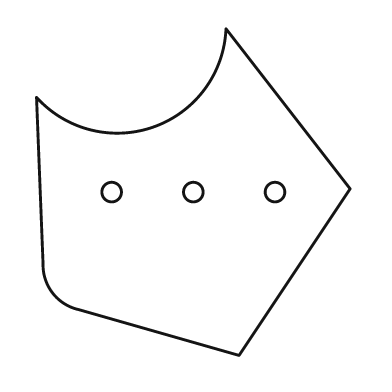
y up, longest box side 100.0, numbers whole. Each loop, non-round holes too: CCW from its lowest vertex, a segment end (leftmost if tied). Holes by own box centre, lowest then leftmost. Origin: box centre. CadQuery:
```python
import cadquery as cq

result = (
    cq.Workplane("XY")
    .moveTo(14.0, -50.0)
    .lineTo(48.0, 1.0)
    .lineTo(10.0, 50.0)
    .threePointArc((-12.0, 20.0), (-48.0, 29.0))
    .lineTo(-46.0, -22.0)
    .threePointArc((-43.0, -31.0), (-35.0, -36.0))
    .close()
    .moveTo(-25.0, 0.0)
    .circle(3.0)
    .moveTo(0.0, 0.0)
    .circle(3.0)
    .moveTo(25.0, 0.0)
    .circle(3.0)
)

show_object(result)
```